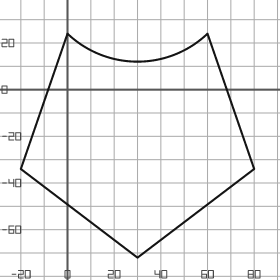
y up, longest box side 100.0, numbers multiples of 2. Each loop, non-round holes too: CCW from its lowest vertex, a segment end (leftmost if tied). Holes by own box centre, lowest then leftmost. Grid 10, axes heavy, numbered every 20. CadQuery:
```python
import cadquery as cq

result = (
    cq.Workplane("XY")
    .moveTo(30.0, -72.0)
    .lineTo(80.0, -34.0)
    .lineTo(60.0, 24.0)
    .threePointArc((30.0, 12.0), (0.0, 24.0))
    .lineTo(-20.0, -34.0)
    .close()
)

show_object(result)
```